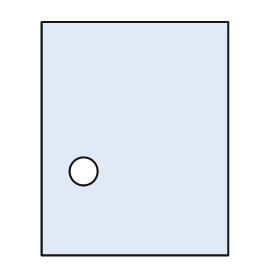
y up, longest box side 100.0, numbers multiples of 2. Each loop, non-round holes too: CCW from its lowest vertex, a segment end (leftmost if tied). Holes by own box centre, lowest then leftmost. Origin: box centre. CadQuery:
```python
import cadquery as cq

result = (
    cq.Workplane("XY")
    .moveTo(-40.0, -50.0)
    .lineTo(40.0, -50.0)
    .lineTo(40.0, 50.0)
    .lineTo(-40.0, 50.0)
    .close()
    .moveTo(-22.0, -14.0)
    .circle(6.0)
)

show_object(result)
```